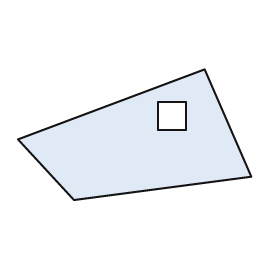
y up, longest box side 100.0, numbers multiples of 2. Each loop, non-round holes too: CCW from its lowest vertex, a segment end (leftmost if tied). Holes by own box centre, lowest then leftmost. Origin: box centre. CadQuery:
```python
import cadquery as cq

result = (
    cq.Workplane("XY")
    .moveTo(-26.0, -28.0)
    .lineTo(50.0, -18.0)
    .lineTo(30.0, 28.0)
    .lineTo(-50.0, -2.0)
    .close()
    .moveTo(10.0, 2.0)
    .lineTo(22.0, 2.0)
    .lineTo(22.0, 14.0)
    .lineTo(10.0, 14.0)
    .close()
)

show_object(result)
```